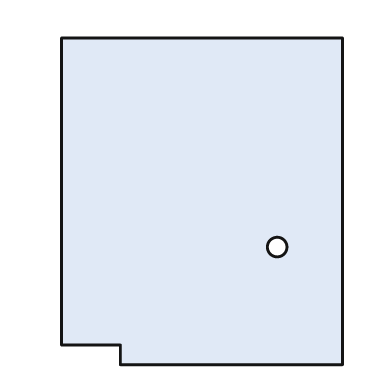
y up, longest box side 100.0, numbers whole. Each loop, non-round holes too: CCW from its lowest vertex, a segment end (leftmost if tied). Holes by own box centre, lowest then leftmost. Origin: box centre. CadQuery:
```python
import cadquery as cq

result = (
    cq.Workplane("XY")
    .moveTo(-25.0, -50.0)
    .lineTo(43.0, -50.0)
    .lineTo(43.0, 50.0)
    .lineTo(-43.0, 50.0)
    .lineTo(-43.0, -44.0)
    .lineTo(-25.0, -44.0)
    .close()
    .moveTo(23.0, -14.0)
    .circle(3.0)
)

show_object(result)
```